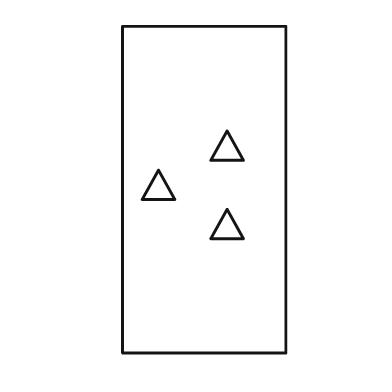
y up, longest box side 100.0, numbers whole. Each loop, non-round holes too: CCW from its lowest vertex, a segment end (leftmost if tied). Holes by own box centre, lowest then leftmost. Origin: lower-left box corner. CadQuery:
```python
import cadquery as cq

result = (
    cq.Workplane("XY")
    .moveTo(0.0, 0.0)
    .lineTo(50.0, 0.0)
    .lineTo(50.0, 100.0)
    .lineTo(0.0, 100.0)
    .close()
    .moveTo(27.0, 35.0)
    .lineTo(37.0, 35.0)
    .lineTo(32.0, 44.0)
    .close()
    .moveTo(6.0, 47.0)
    .lineTo(16.0, 47.0)
    .lineTo(11.0, 56.0)
    .close()
    .moveTo(27.0, 59.0)
    .lineTo(37.0, 59.0)
    .lineTo(32.0, 68.0)
    .close()
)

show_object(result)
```